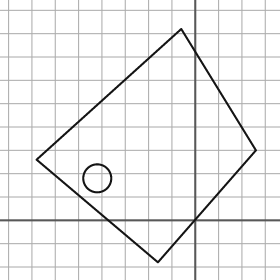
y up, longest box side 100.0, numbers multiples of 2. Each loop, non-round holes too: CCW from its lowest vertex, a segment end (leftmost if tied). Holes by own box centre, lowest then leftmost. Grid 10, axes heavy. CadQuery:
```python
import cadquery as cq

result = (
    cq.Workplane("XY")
    .moveTo(-16.0, -18.0)
    .lineTo(26.0, 30.0)
    .lineTo(-6.0, 82.0)
    .lineTo(-68.0, 26.0)
    .close()
    .moveTo(-42.0, 18.0)
    .circle(6.0)
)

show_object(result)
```